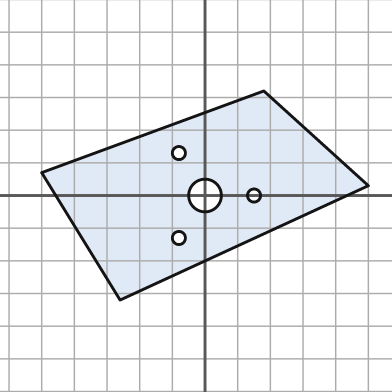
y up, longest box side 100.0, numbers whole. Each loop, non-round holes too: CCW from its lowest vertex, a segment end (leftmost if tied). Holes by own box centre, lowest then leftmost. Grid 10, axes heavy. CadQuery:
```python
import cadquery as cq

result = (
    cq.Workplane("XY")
    .moveTo(-26.0, -32.0)
    .lineTo(50.0, 3.0)
    .lineTo(18.0, 32.0)
    .lineTo(-50.0, 7.0)
    .close()
    .moveTo(-8.0, -13.0)
    .circle(2.0)
    .moveTo(0.0, 0.0)
    .circle(5.0)
    .moveTo(15.0, 0.0)
    .circle(2.0)
    .moveTo(-8.0, 13.0)
    .circle(2.0)
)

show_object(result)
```